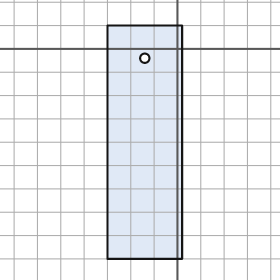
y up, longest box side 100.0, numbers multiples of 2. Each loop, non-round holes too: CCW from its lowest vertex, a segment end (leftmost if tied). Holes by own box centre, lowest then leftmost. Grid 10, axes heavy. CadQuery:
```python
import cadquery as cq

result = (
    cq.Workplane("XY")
    .moveTo(-30.0, -90.0)
    .lineTo(2.0, -90.0)
    .lineTo(2.0, 10.0)
    .lineTo(-30.0, 10.0)
    .close()
    .moveTo(-14.0, -4.0)
    .circle(2.0)
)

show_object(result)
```